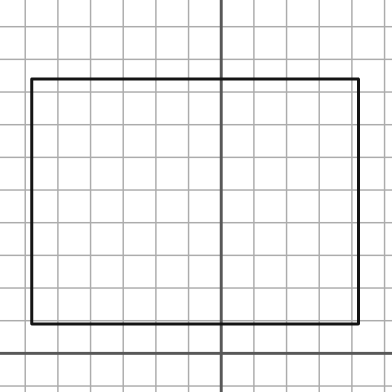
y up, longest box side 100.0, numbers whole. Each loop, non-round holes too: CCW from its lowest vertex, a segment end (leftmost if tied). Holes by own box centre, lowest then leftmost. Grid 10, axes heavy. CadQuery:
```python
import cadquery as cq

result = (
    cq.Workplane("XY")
    .moveTo(-58.0, 9.0)
    .lineTo(42.0, 9.0)
    .lineTo(42.0, 84.0)
    .lineTo(-58.0, 84.0)
    .close()
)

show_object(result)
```